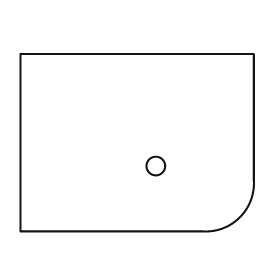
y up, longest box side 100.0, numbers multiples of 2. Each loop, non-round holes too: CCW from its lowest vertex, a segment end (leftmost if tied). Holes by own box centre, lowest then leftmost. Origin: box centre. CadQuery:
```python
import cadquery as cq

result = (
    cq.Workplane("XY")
    .moveTo(-50.0, -38.0)
    .lineTo(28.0, -38.0)
    .threePointArc((44.0, -32.0), (50.0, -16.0))
    .lineTo(50.0, 38.0)
    .lineTo(-50.0, 38.0)
    .close()
    .moveTo(8.0, -10.0)
    .circle(4.0)
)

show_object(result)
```